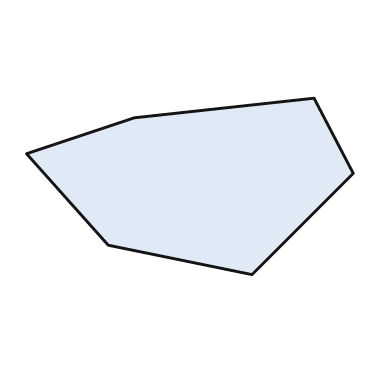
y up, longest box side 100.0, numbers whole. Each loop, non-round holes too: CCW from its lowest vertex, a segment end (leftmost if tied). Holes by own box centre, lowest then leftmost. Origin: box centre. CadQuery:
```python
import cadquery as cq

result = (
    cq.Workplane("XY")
    .moveTo(19.0, -27.0)
    .lineTo(50.0, 4.0)
    .lineTo(38.0, 27.0)
    .lineTo(-17.0, 21.0)
    .lineTo(-50.0, 10.0)
    .lineTo(-25.0, -18.0)
    .close()
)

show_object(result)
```